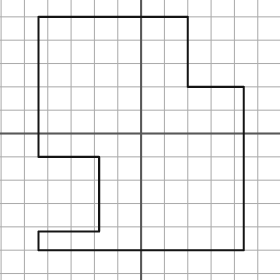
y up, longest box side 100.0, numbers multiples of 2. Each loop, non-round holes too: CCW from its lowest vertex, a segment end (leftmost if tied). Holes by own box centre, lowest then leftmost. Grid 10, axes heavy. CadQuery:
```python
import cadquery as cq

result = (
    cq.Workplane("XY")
    .moveTo(-44.0, -50.0)
    .lineTo(44.0, -50.0)
    .lineTo(44.0, 20.0)
    .lineTo(20.0, 20.0)
    .lineTo(20.0, 50.0)
    .lineTo(-44.0, 50.0)
    .lineTo(-44.0, -10.0)
    .lineTo(-18.0, -10.0)
    .lineTo(-18.0, -42.0)
    .lineTo(-44.0, -42.0)
    .close()
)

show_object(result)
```